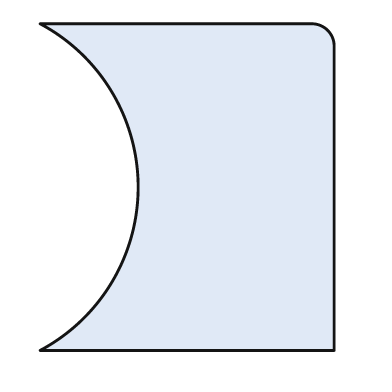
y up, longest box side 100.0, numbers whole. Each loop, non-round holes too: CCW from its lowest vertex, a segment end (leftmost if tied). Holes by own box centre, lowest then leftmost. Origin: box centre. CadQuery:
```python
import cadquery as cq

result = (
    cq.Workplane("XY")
    .moveTo(-45.0, -50.0)
    .lineTo(45.0, -50.0)
    .lineTo(45.0, 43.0)
    .threePointArc((43.0, 48.0), (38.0, 50.0))
    .lineTo(-45.0, 50.0)
    .threePointArc((-15.0, 0.0), (-45.0, -50.0))
    .close()
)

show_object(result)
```